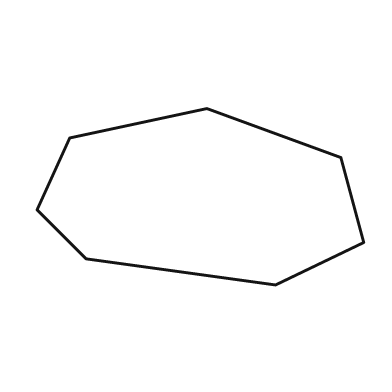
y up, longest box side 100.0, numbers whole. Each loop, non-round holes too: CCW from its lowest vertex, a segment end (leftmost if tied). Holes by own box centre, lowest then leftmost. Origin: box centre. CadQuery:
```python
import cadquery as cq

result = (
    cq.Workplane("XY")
    .moveTo(23.0, -27.0)
    .lineTo(50.0, -14.0)
    .lineTo(43.0, 12.0)
    .lineTo(2.0, 27.0)
    .lineTo(-40.0, 18.0)
    .lineTo(-50.0, -4.0)
    .lineTo(-35.0, -19.0)
    .close()
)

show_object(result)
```